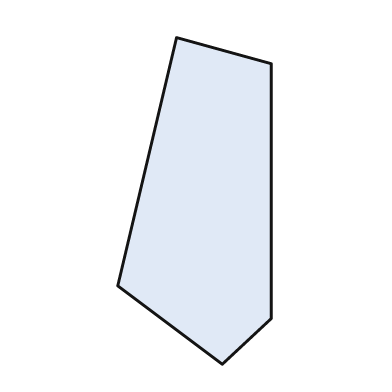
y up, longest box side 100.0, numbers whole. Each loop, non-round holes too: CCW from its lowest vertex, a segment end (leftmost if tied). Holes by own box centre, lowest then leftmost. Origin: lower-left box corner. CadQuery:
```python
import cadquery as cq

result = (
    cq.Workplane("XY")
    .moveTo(32.0, 0.0)
    .lineTo(47.0, 14.0)
    .lineTo(47.0, 92.0)
    .lineTo(18.0, 100.0)
    .lineTo(0.0, 24.0)
    .close()
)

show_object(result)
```